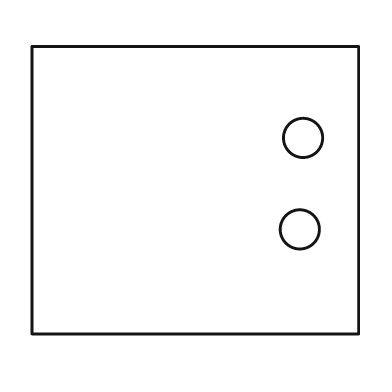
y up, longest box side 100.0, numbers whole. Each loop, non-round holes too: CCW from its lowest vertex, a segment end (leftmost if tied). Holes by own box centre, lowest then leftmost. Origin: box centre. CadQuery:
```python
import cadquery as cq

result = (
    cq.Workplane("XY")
    .moveTo(-50.0, -44.0)
    .lineTo(50.0, -44.0)
    .lineTo(50.0, 44.0)
    .lineTo(-50.0, 44.0)
    .close()
    .moveTo(32.0, -12.0)
    .circle(6.0)
    .moveTo(33.0, 16.0)
    .circle(6.0)
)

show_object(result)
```